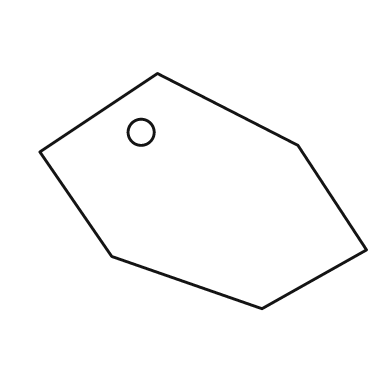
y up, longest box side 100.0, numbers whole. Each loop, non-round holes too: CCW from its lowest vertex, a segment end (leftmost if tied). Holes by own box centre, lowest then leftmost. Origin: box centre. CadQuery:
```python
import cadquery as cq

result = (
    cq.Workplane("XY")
    .moveTo(18.0, -36.0)
    .lineTo(50.0, -18.0)
    .lineTo(29.0, 14.0)
    .lineTo(-14.0, 36.0)
    .lineTo(-50.0, 12.0)
    .lineTo(-28.0, -20.0)
    .close()
    .moveTo(-19.0, 18.0)
    .circle(4.0)
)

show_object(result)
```